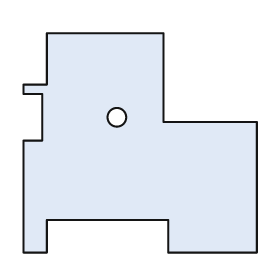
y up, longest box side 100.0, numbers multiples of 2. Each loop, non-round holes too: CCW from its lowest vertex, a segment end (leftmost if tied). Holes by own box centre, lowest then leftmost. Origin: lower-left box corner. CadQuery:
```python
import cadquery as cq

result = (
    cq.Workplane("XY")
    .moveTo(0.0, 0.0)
    .lineTo(10.0, 0.0)
    .lineTo(10.0, 14.0)
    .lineTo(62.0, 14.0)
    .lineTo(62.0, 0.0)
    .lineTo(100.0, 0.0)
    .lineTo(100.0, 56.0)
    .lineTo(60.0, 56.0)
    .lineTo(60.0, 94.0)
    .lineTo(10.0, 94.0)
    .lineTo(10.0, 72.0)
    .lineTo(0.0, 72.0)
    .lineTo(0.0, 68.0)
    .lineTo(8.0, 68.0)
    .lineTo(8.0, 48.0)
    .lineTo(0.0, 48.0)
    .close()
    .moveTo(40.0, 58.0)
    .circle(4.0)
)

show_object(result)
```